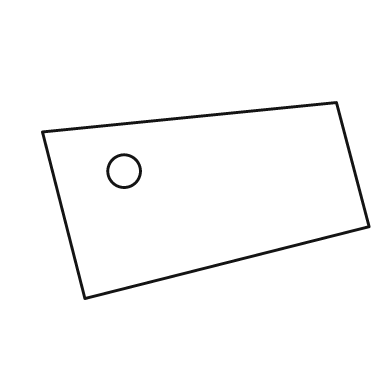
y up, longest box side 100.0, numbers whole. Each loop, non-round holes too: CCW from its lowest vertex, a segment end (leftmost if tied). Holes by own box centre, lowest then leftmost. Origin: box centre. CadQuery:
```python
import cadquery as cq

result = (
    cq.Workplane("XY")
    .moveTo(-37.0, -30.0)
    .lineTo(50.0, -8.0)
    .lineTo(40.0, 30.0)
    .lineTo(-50.0, 21.0)
    .close()
    .moveTo(-25.0, 9.0)
    .circle(5.0)
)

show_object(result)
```